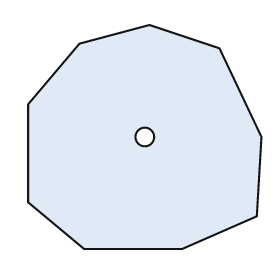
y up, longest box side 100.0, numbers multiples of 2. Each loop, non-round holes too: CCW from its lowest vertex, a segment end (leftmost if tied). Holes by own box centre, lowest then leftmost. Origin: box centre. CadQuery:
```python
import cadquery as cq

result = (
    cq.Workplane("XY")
    .moveTo(-26.0, -48.0)
    .lineTo(16.0, -48.0)
    .lineTo(48.0, -34.0)
    .lineTo(50.0, 0.0)
    .lineTo(32.0, 38.0)
    .lineTo(2.0, 48.0)
    .lineTo(-28.0, 40.0)
    .lineTo(-50.0, 14.0)
    .lineTo(-50.0, -28.0)
    .close()
    .moveTo(0.0, 0.0)
    .circle(4.0)
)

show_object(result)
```